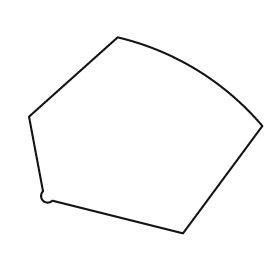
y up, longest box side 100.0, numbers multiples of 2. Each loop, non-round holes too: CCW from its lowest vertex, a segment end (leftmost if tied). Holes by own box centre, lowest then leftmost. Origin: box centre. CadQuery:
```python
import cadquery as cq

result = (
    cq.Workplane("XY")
    .moveTo(16.0, -42.0)
    .lineTo(50.0, 4.0)
    .threePointArc((22.0, 28.0), (-12.0, 42.0))
    .lineTo(-50.0, 8.0)
    .lineTo(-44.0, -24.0)
    .threePointArc((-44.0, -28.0), (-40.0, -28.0))
    .close()
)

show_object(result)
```